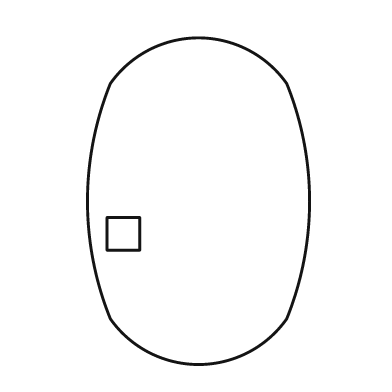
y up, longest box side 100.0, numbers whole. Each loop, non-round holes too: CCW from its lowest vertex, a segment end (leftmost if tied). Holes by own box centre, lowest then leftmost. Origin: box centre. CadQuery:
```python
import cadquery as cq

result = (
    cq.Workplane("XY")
    .moveTo(-27.0, -36.0)
    .threePointArc((0.0, -50.0), (27.0, -36.0))
    .threePointArc((34.0, 0.0), (27.0, 36.0))
    .threePointArc((0.0, 50.0), (-27.0, 36.0))
    .threePointArc((-34.0, 0.0), (-27.0, -36.0))
    .close()
    .moveTo(-28.0, -15.0)
    .lineTo(-18.0, -15.0)
    .lineTo(-18.0, -5.0)
    .lineTo(-28.0, -5.0)
    .close()
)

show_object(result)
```